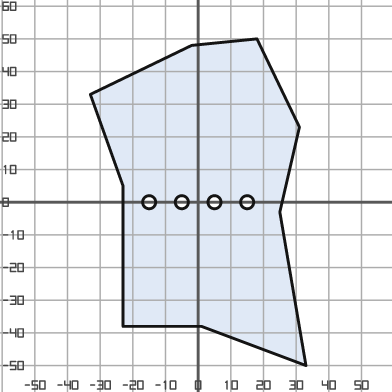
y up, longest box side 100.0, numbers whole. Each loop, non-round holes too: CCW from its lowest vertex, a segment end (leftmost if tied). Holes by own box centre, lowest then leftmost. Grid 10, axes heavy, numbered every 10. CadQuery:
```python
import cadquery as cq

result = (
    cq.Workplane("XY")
    .moveTo(33.0, -50.0)
    .lineTo(25.0, -3.0)
    .lineTo(31.0, 23.0)
    .lineTo(18.0, 50.0)
    .lineTo(-2.0, 48.0)
    .lineTo(-33.0, 33.0)
    .lineTo(-23.0, 5.0)
    .lineTo(-23.0, -38.0)
    .lineTo(1.0, -38.0)
    .close()
    .moveTo(-15.0, 0.0)
    .circle(2.0)
    .moveTo(-5.0, 0.0)
    .circle(2.0)
    .moveTo(5.0, 0.0)
    .circle(2.0)
    .moveTo(15.0, 0.0)
    .circle(2.0)
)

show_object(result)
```